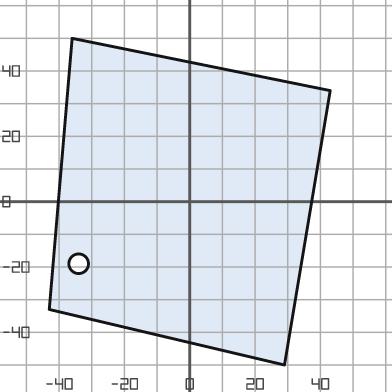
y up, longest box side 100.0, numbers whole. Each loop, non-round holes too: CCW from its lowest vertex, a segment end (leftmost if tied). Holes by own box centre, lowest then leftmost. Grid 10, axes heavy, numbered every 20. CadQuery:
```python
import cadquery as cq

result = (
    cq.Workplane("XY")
    .moveTo(29.0, -50.0)
    .lineTo(43.0, 34.0)
    .lineTo(-36.0, 50.0)
    .lineTo(-43.0, -33.0)
    .close()
    .moveTo(-34.0, -19.0)
    .circle(3.0)
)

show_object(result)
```